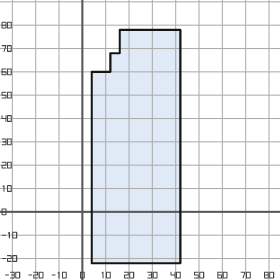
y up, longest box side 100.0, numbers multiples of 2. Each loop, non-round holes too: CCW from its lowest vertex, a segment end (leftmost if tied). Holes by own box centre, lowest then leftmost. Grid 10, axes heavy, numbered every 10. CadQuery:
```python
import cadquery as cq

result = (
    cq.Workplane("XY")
    .moveTo(4.0, -22.0)
    .lineTo(42.0, -22.0)
    .lineTo(42.0, 78.0)
    .lineTo(16.0, 78.0)
    .lineTo(16.0, 68.0)
    .lineTo(12.0, 68.0)
    .lineTo(12.0, 60.0)
    .lineTo(4.0, 60.0)
    .close()
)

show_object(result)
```